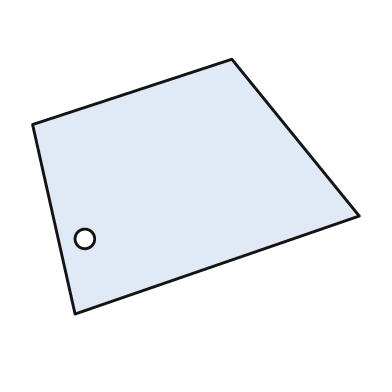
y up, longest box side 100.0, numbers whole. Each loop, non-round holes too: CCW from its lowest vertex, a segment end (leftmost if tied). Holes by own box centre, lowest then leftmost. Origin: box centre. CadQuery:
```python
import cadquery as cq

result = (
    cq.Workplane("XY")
    .moveTo(-37.0, -39.0)
    .lineTo(50.0, -9.0)
    .lineTo(11.0, 39.0)
    .lineTo(-50.0, 19.0)
    .close()
    .moveTo(-34.0, -16.0)
    .circle(3.0)
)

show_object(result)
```